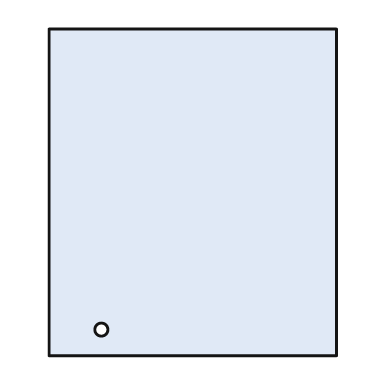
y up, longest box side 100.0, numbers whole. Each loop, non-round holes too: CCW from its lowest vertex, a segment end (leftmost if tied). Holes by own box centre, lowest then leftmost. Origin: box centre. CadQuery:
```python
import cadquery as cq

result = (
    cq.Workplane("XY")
    .moveTo(-44.0, -50.0)
    .lineTo(44.0, -50.0)
    .lineTo(44.0, 50.0)
    .lineTo(-44.0, 50.0)
    .close()
    .moveTo(-28.0, -42.0)
    .circle(2.0)
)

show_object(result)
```